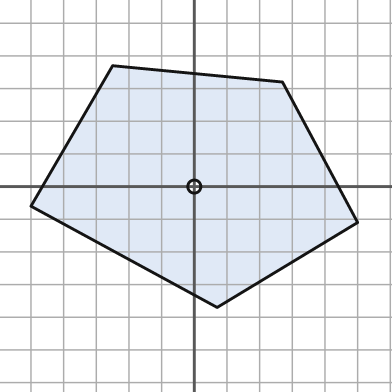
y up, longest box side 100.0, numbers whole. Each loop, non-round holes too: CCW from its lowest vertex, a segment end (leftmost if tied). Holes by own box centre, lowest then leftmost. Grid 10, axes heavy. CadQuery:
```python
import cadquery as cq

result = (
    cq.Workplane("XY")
    .moveTo(7.0, -37.0)
    .lineTo(50.0, -11.0)
    .lineTo(27.0, 32.0)
    .lineTo(-25.0, 37.0)
    .lineTo(-50.0, -6.0)
    .close()
    .moveTo(0.0, 0.0)
    .circle(2.0)
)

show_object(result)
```